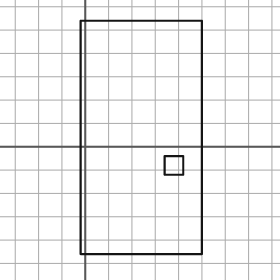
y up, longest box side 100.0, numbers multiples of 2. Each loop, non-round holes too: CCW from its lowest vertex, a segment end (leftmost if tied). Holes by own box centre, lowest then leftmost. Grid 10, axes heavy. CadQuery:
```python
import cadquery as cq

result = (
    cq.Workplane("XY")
    .moveTo(-2.0, -46.0)
    .lineTo(50.0, -46.0)
    .lineTo(50.0, 54.0)
    .lineTo(-2.0, 54.0)
    .close()
    .moveTo(34.0, -12.0)
    .lineTo(42.0, -12.0)
    .lineTo(42.0, -4.0)
    .lineTo(34.0, -4.0)
    .close()
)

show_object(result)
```